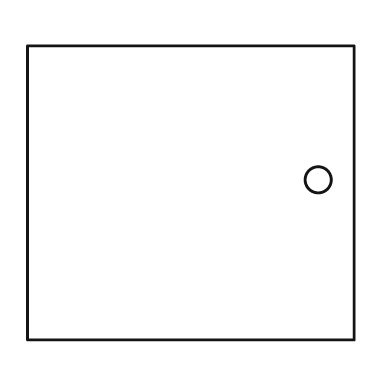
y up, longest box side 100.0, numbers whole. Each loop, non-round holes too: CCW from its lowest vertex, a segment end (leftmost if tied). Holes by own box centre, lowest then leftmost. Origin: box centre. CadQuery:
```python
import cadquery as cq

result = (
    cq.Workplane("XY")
    .moveTo(-50.0, -45.0)
    .lineTo(50.0, -45.0)
    .lineTo(50.0, 45.0)
    .lineTo(-50.0, 45.0)
    .close()
    .moveTo(39.0, 4.0)
    .circle(4.0)
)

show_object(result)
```